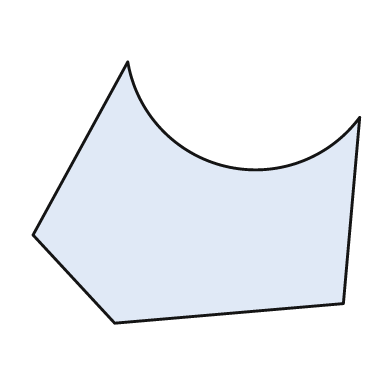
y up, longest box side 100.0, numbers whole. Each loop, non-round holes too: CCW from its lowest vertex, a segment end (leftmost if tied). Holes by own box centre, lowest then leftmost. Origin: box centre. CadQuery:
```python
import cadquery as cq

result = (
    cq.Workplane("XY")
    .moveTo(-25.0, -40.0)
    .lineTo(45.0, -34.0)
    .lineTo(50.0, 23.0)
    .threePointArc((9.0, 8.0), (-21.0, 40.0))
    .lineTo(-50.0, -13.0)
    .close()
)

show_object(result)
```